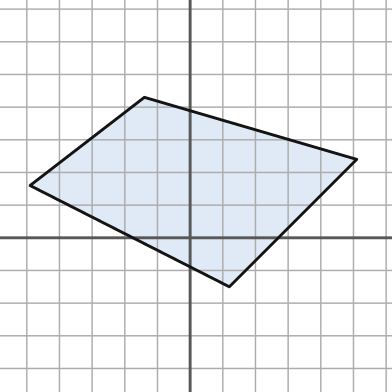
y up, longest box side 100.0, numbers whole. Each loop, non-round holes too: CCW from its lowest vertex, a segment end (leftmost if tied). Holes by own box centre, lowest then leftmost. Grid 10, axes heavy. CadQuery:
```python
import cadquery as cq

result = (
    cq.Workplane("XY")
    .moveTo(12.0, -15.0)
    .lineTo(51.0, 24.0)
    .lineTo(-14.0, 43.0)
    .lineTo(-49.0, 16.0)
    .close()
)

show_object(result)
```